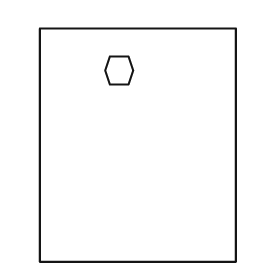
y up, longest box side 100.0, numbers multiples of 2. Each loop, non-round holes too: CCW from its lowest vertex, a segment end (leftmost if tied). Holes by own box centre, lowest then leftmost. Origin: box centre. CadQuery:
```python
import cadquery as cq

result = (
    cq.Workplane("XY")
    .moveTo(-42.0, -50.0)
    .lineTo(42.0, -50.0)
    .lineTo(42.0, 50.0)
    .lineTo(-42.0, 50.0)
    .close()
    .moveTo(-12.0, 26.0)
    .lineTo(-4.0, 26.0)
    .lineTo(-2.0, 32.0)
    .lineTo(-4.0, 38.0)
    .lineTo(-12.0, 38.0)
    .lineTo(-14.0, 32.0)
    .close()
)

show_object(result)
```